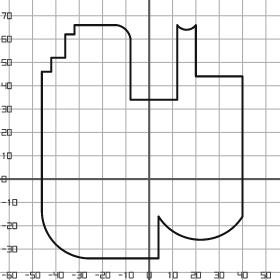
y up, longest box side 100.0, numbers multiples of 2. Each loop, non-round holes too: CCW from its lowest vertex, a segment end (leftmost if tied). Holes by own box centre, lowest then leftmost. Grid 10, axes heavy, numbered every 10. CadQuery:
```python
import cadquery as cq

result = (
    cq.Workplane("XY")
    .moveTo(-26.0, -34.0)
    .lineTo(4.0, -34.0)
    .lineTo(4.0, -16.0)
    .threePointArc((22.0, -26.0), (40.0, -16.0))
    .lineTo(40.0, 44.0)
    .lineTo(20.0, 44.0)
    .lineTo(20.0, 66.0)
    .threePointArc((16.0, 64.0), (12.0, 66.0))
    .lineTo(12.0, 34.0)
    .lineTo(-8.0, 34.0)
    .lineTo(-8.0, 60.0)
    .threePointArc((-10.0, 64.0), (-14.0, 66.0))
    .lineTo(-32.0, 66.0)
    .lineTo(-32.0, 62.0)
    .lineTo(-36.0, 62.0)
    .lineTo(-36.0, 52.0)
    .lineTo(-42.0, 52.0)
    .lineTo(-42.0, 46.0)
    .lineTo(-46.0, 46.0)
    .lineTo(-46.0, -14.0)
    .threePointArc((-40.0, -28.0), (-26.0, -34.0))
    .close()
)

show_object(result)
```